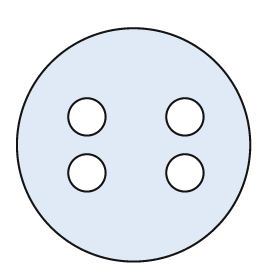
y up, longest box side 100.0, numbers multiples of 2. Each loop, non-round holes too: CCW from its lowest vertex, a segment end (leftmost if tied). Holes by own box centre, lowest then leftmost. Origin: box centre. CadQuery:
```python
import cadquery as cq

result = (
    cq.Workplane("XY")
    .moveTo(0.0, 0.0)
    .circle(50.0)
    .moveTo(-20.0, -12.0)
    .circle(8.0)
    .moveTo(22.0, -12.0)
    .circle(8.0)
    .moveTo(-20.0, 12.0)
    .circle(8.0)
    .moveTo(22.0, 12.0)
    .circle(8.0)
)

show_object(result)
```